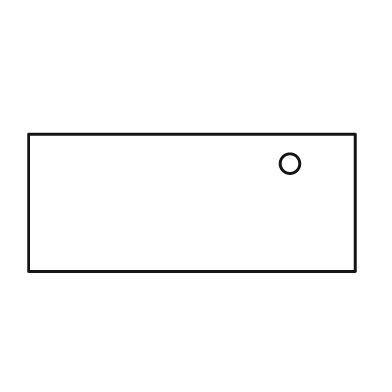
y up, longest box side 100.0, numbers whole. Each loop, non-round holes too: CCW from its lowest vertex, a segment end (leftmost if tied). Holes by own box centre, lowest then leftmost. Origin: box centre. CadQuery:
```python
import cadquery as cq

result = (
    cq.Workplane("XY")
    .moveTo(-50.0, -21.0)
    .lineTo(50.0, -21.0)
    .lineTo(50.0, 21.0)
    .lineTo(-50.0, 21.0)
    .close()
    .moveTo(30.0, 12.0)
    .circle(3.0)
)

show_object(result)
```